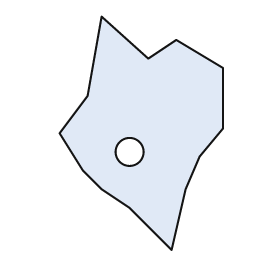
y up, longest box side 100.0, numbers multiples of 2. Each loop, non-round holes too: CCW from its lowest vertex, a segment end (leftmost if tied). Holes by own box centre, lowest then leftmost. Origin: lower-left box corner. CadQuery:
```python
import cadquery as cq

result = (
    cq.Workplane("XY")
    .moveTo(48.0, 0.0)
    .lineTo(54.0, 26.0)
    .lineTo(60.0, 40.0)
    .lineTo(70.0, 52.0)
    .lineTo(70.0, 78.0)
    .lineTo(50.0, 90.0)
    .lineTo(38.0, 82.0)
    .lineTo(18.0, 100.0)
    .lineTo(12.0, 66.0)
    .lineTo(0.0, 50.0)
    .lineTo(10.0, 34.0)
    .lineTo(18.0, 26.0)
    .lineTo(30.0, 18.0)
    .close()
    .moveTo(30.0, 42.0)
    .circle(6.0)
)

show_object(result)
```